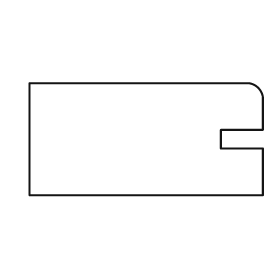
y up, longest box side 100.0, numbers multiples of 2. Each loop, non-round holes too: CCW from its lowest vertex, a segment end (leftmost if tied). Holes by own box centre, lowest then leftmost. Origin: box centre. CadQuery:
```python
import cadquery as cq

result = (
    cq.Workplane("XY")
    .moveTo(-50.0, -24.0)
    .lineTo(50.0, -24.0)
    .lineTo(50.0, -4.0)
    .lineTo(32.0, -4.0)
    .lineTo(32.0, 4.0)
    .lineTo(50.0, 4.0)
    .lineTo(50.0, 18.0)
    .threePointArc((48.0, 22.0), (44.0, 24.0))
    .lineTo(-50.0, 24.0)
    .close()
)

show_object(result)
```